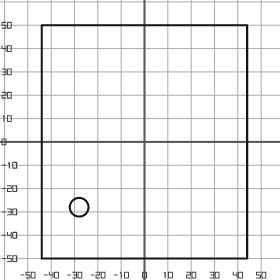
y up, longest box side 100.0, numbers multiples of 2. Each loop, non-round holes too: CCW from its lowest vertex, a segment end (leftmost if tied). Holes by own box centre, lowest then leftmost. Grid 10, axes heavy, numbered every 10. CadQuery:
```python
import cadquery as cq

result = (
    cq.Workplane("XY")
    .moveTo(-44.0, -50.0)
    .lineTo(44.0, -50.0)
    .lineTo(44.0, 50.0)
    .lineTo(-44.0, 50.0)
    .close()
    .moveTo(-28.0, -28.0)
    .circle(4.0)
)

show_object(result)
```